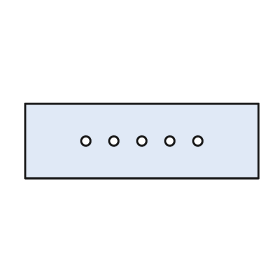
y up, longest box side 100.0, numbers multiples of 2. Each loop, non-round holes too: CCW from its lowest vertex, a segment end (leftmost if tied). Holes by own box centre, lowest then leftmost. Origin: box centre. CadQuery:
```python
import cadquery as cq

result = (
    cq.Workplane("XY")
    .moveTo(-50.0, -16.0)
    .lineTo(50.0, -16.0)
    .lineTo(50.0, 16.0)
    .lineTo(-50.0, 16.0)
    .close()
    .moveTo(-24.0, 0.0)
    .circle(2.0)
    .moveTo(-12.0, 0.0)
    .circle(2.0)
    .moveTo(0.0, 0.0)
    .circle(2.0)
    .moveTo(12.0, 0.0)
    .circle(2.0)
    .moveTo(24.0, 0.0)
    .circle(2.0)
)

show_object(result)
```